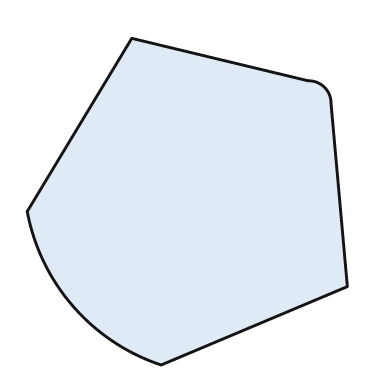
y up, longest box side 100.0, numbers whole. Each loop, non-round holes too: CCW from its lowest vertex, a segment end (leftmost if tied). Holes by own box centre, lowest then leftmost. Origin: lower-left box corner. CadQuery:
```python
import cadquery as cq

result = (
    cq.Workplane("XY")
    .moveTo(41.0, 0.0)
    .lineTo(98.0, 24.0)
    .lineTo(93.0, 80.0)
    .threePointArc((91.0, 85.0), (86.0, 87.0))
    .lineTo(32.0, 100.0)
    .lineTo(0.0, 47.0)
    .threePointArc((14.0, 18.0), (41.0, 0.0))
    .close()
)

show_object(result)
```